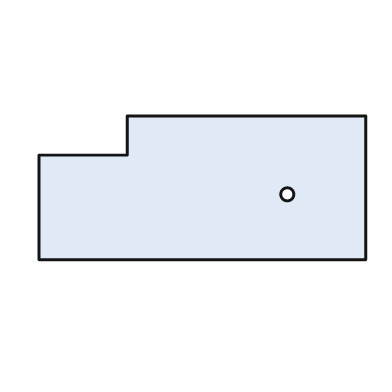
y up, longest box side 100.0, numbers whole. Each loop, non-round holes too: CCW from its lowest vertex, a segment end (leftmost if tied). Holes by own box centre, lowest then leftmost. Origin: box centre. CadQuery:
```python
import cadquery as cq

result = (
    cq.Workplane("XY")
    .moveTo(-50.0, -22.0)
    .lineTo(50.0, -22.0)
    .lineTo(50.0, 22.0)
    .lineTo(-23.0, 22.0)
    .lineTo(-23.0, 10.0)
    .lineTo(-50.0, 10.0)
    .close()
    .moveTo(26.0, -2.0)
    .circle(2.0)
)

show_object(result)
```